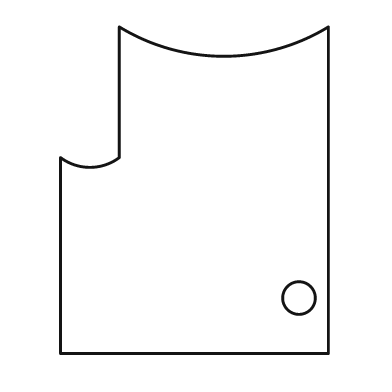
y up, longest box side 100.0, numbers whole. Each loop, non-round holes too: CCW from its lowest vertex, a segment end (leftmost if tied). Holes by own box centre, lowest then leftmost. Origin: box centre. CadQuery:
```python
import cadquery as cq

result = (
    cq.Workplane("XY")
    .moveTo(-41.0, -50.0)
    .lineTo(41.0, -50.0)
    .lineTo(41.0, 50.0)
    .threePointArc((9.0, 41.0), (-23.0, 50.0))
    .lineTo(-23.0, 10.0)
    .threePointArc((-32.0, 7.0), (-41.0, 10.0))
    .close()
    .moveTo(32.0, -33.0)
    .circle(5.0)
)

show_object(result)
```